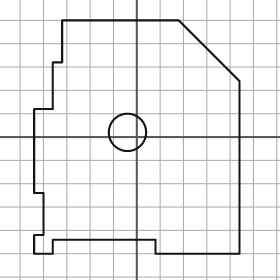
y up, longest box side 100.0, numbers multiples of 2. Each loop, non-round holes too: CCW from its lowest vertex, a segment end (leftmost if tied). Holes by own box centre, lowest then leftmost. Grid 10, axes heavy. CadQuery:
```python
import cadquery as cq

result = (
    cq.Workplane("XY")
    .moveTo(-44.0, -50.0)
    .lineTo(-36.0, -50.0)
    .lineTo(-36.0, -44.0)
    .lineTo(8.0, -44.0)
    .lineTo(8.0, -50.0)
    .lineTo(44.0, -50.0)
    .lineTo(44.0, 24.0)
    .lineTo(18.0, 50.0)
    .lineTo(-32.0, 50.0)
    .lineTo(-32.0, 32.0)
    .lineTo(-36.0, 32.0)
    .lineTo(-36.0, 12.0)
    .lineTo(-44.0, 12.0)
    .lineTo(-44.0, -24.0)
    .lineTo(-40.0, -24.0)
    .lineTo(-40.0, -42.0)
    .lineTo(-44.0, -42.0)
    .close()
    .moveTo(-4.0, 2.0)
    .circle(8.0)
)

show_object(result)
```